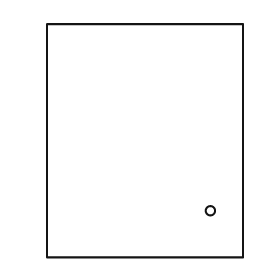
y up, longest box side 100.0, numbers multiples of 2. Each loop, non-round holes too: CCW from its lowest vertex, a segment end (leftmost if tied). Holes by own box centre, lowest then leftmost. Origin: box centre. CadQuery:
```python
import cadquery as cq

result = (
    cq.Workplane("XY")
    .moveTo(-42.0, -50.0)
    .lineTo(42.0, -50.0)
    .lineTo(42.0, 50.0)
    .lineTo(-42.0, 50.0)
    .close()
    .moveTo(28.0, -30.0)
    .circle(2.0)
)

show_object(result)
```